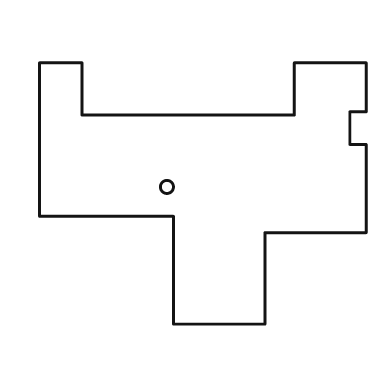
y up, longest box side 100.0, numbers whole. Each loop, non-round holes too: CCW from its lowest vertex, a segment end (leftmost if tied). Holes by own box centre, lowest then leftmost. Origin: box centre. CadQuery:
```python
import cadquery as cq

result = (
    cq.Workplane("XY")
    .moveTo(-9.0, -40.0)
    .lineTo(19.0, -40.0)
    .lineTo(19.0, -12.0)
    .lineTo(50.0, -12.0)
    .lineTo(50.0, 15.0)
    .lineTo(45.0, 15.0)
    .lineTo(45.0, 25.0)
    .lineTo(50.0, 25.0)
    .lineTo(50.0, 40.0)
    .lineTo(28.0, 40.0)
    .lineTo(28.0, 24.0)
    .lineTo(-37.0, 24.0)
    .lineTo(-37.0, 40.0)
    .lineTo(-50.0, 40.0)
    .lineTo(-50.0, -7.0)
    .lineTo(-9.0, -7.0)
    .close()
    .moveTo(-11.0, 2.0)
    .circle(2.0)
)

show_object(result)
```